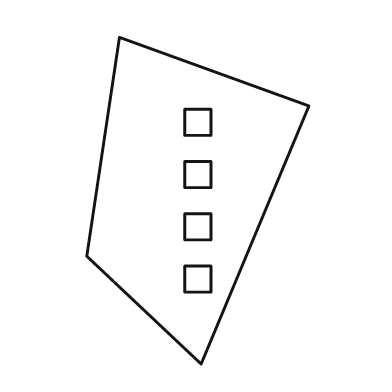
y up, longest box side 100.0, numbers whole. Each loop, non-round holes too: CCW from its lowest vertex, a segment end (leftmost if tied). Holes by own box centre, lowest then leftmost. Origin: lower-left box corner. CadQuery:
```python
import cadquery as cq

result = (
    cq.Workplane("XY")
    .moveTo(35.0, 0.0)
    .lineTo(68.0, 79.0)
    .lineTo(10.0, 100.0)
    .lineTo(0.0, 33.0)
    .close()
    .moveTo(30.0, 22.0)
    .lineTo(38.0, 22.0)
    .lineTo(38.0, 30.0)
    .lineTo(30.0, 30.0)
    .close()
    .moveTo(30.0, 38.0)
    .lineTo(38.0, 38.0)
    .lineTo(38.0, 46.0)
    .lineTo(30.0, 46.0)
    .close()
    .moveTo(30.0, 54.0)
    .lineTo(38.0, 54.0)
    .lineTo(38.0, 62.0)
    .lineTo(30.0, 62.0)
    .close()
    .moveTo(30.0, 70.0)
    .lineTo(38.0, 70.0)
    .lineTo(38.0, 78.0)
    .lineTo(30.0, 78.0)
    .close()
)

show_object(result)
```